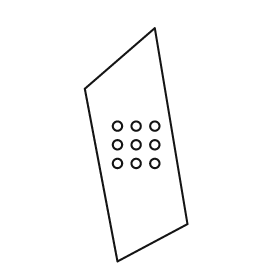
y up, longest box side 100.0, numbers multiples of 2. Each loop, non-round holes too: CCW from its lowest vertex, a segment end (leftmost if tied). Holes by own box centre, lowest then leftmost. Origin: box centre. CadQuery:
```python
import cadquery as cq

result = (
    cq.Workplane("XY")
    .moveTo(-8.0, -50.0)
    .lineTo(22.0, -34.0)
    .lineTo(8.0, 50.0)
    .lineTo(-22.0, 24.0)
    .close()
    .moveTo(-8.0, -8.0)
    .circle(2.0)
    .moveTo(0.0, -8.0)
    .circle(2.0)
    .moveTo(8.0, -8.0)
    .circle(2.0)
    .moveTo(-8.0, 0.0)
    .circle(2.0)
    .moveTo(0.0, 0.0)
    .circle(2.0)
    .moveTo(8.0, 0.0)
    .circle(2.0)
    .moveTo(-8.0, 8.0)
    .circle(2.0)
    .moveTo(0.0, 8.0)
    .circle(2.0)
    .moveTo(8.0, 8.0)
    .circle(2.0)
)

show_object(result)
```